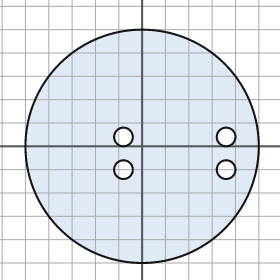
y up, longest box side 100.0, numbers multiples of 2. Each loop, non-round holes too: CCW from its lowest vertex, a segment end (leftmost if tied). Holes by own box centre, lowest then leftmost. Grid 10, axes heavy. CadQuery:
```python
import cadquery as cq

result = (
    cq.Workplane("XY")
    .moveTo(0.0, 0.0)
    .circle(50.0)
    .moveTo(-8.0, -10.0)
    .circle(4.0)
    .moveTo(36.0, -10.0)
    .circle(4.0)
    .moveTo(-8.0, 4.0)
    .circle(4.0)
    .moveTo(36.0, 4.0)
    .circle(4.0)
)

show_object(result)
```